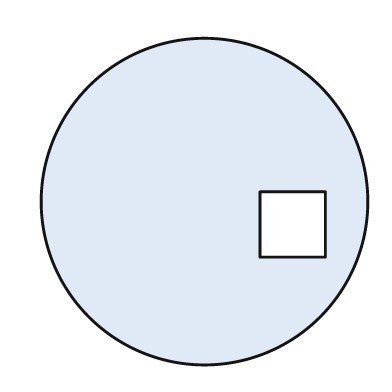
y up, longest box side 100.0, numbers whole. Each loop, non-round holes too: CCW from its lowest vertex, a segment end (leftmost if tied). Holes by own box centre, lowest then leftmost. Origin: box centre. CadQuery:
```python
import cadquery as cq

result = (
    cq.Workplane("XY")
    .moveTo(0.0, 0.0)
    .circle(50.0)
    .moveTo(17.0, -17.0)
    .lineTo(37.0, -17.0)
    .lineTo(37.0, 3.0)
    .lineTo(17.0, 3.0)
    .close()
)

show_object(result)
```